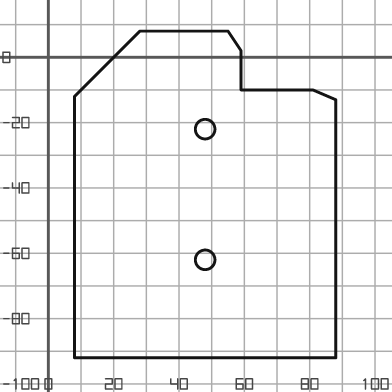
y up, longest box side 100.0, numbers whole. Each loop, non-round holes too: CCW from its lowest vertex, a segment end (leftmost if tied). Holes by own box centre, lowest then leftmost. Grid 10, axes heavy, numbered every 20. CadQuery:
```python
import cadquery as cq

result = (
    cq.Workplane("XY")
    .moveTo(8.0, -92.0)
    .lineTo(88.0, -92.0)
    .lineTo(88.0, -13.0)
    .lineTo(81.0, -10.0)
    .lineTo(59.0, -10.0)
    .lineTo(59.0, 2.0)
    .lineTo(55.0, 8.0)
    .lineTo(28.0, 8.0)
    .lineTo(8.0, -12.0)
    .close()
    .moveTo(48.0, -62.0)
    .circle(3.0)
    .moveTo(48.0, -22.0)
    .circle(3.0)
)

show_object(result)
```